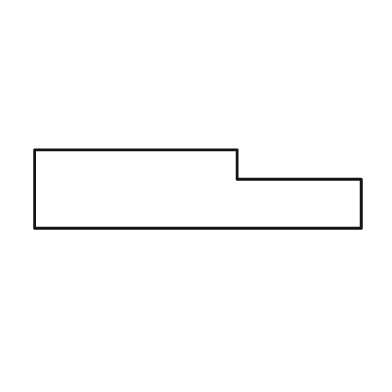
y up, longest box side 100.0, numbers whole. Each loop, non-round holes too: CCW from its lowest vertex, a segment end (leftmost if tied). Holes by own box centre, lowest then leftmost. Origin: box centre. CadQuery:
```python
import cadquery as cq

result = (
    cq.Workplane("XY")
    .moveTo(-50.0, -12.0)
    .lineTo(50.0, -12.0)
    .lineTo(50.0, 3.0)
    .lineTo(12.0, 3.0)
    .lineTo(12.0, 12.0)
    .lineTo(-50.0, 12.0)
    .close()
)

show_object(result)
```